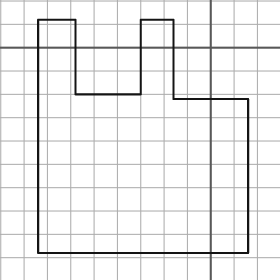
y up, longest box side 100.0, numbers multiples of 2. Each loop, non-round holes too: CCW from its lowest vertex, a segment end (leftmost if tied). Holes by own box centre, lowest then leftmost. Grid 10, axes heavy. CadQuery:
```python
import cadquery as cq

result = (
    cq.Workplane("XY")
    .moveTo(-74.0, -88.0)
    .lineTo(16.0, -88.0)
    .lineTo(16.0, -22.0)
    .lineTo(-16.0, -22.0)
    .lineTo(-16.0, 12.0)
    .lineTo(-30.0, 12.0)
    .lineTo(-30.0, -20.0)
    .lineTo(-58.0, -20.0)
    .lineTo(-58.0, 12.0)
    .lineTo(-74.0, 12.0)
    .close()
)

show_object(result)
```